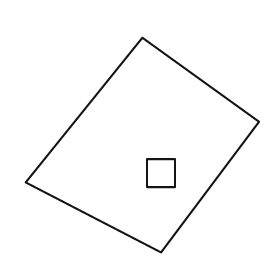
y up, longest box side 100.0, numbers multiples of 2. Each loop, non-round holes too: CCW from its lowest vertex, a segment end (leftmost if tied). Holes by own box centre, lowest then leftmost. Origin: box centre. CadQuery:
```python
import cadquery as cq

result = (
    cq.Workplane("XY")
    .moveTo(8.0, -46.0)
    .lineTo(50.0, 10.0)
    .lineTo(0.0, 46.0)
    .lineTo(-50.0, -16.0)
    .close()
    .moveTo(2.0, -18.0)
    .lineTo(14.0, -18.0)
    .lineTo(14.0, -6.0)
    .lineTo(2.0, -6.0)
    .close()
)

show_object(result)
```